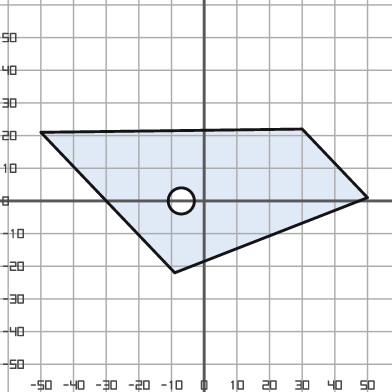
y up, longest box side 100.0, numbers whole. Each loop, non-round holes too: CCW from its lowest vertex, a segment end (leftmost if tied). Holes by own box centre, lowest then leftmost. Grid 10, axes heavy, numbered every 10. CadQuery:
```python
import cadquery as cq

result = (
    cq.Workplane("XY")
    .moveTo(-9.0, -22.0)
    .lineTo(50.0, 1.0)
    .lineTo(30.0, 22.0)
    .lineTo(-50.0, 21.0)
    .close()
    .moveTo(-7.0, 0.0)
    .circle(4.0)
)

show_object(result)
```